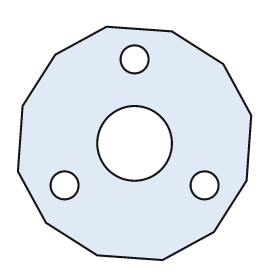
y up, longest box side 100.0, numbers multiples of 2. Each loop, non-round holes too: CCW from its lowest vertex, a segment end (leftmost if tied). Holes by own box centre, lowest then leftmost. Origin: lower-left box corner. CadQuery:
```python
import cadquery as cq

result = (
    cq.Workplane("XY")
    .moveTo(62.0, 0.0)
    .lineTo(84.0, 12.0)
    .lineTo(98.0, 34.0)
    .lineTo(100.0, 62.0)
    .lineTo(88.0, 84.0)
    .lineTo(66.0, 98.0)
    .lineTo(38.0, 100.0)
    .lineTo(16.0, 88.0)
    .lineTo(2.0, 66.0)
    .lineTo(0.0, 38.0)
    .lineTo(12.0, 16.0)
    .lineTo(34.0, 2.0)
    .close()
    .moveTo(20.0, 32.0)
    .circle(6.0)
    .moveTo(80.0, 32.0)
    .circle(6.0)
    .moveTo(50.0, 50.0)
    .circle(16.0)
    .moveTo(50.0, 86.0)
    .circle(6.0)
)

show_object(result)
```